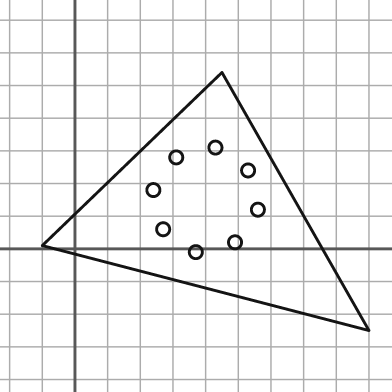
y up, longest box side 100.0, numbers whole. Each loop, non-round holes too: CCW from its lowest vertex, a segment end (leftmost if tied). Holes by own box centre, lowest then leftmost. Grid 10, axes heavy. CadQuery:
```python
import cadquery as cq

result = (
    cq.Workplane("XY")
    .moveTo(90.0, -25.0)
    .lineTo(45.0, 54.0)
    .lineTo(-10.0, 1.0)
    .close()
    .moveTo(37.0, -1.0)
    .circle(2.0)
    .moveTo(49.0, 2.0)
    .circle(2.0)
    .moveTo(27.0, 6.0)
    .circle(2.0)
    .moveTo(56.0, 12.0)
    .circle(2.0)
    .moveTo(24.0, 18.0)
    .circle(2.0)
    .moveTo(53.0, 24.0)
    .circle(2.0)
    .moveTo(31.0, 28.0)
    .circle(2.0)
    .moveTo(43.0, 31.0)
    .circle(2.0)
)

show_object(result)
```